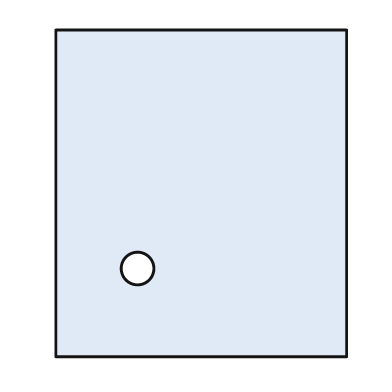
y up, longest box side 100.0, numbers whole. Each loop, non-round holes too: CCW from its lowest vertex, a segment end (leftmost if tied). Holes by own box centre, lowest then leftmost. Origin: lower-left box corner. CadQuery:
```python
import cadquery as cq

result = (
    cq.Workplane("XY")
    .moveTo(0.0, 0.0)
    .lineTo(89.0, 0.0)
    .lineTo(89.0, 100.0)
    .lineTo(0.0, 100.0)
    .close()
    .moveTo(25.0, 27.0)
    .circle(5.0)
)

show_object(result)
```